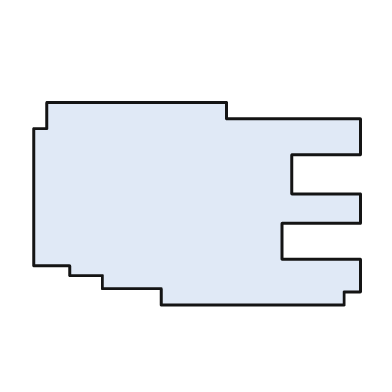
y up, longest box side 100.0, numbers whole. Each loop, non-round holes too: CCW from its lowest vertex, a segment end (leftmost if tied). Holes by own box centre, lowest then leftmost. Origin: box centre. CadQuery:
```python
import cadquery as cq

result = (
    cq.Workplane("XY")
    .moveTo(-11.0, -31.0)
    .lineTo(45.0, -31.0)
    .lineTo(45.0, -27.0)
    .lineTo(50.0, -27.0)
    .lineTo(50.0, -17.0)
    .lineTo(26.0, -17.0)
    .lineTo(26.0, -6.0)
    .lineTo(50.0, -6.0)
    .lineTo(50.0, 3.0)
    .lineTo(29.0, 3.0)
    .lineTo(29.0, 15.0)
    .lineTo(50.0, 15.0)
    .lineTo(50.0, 26.0)
    .lineTo(9.0, 26.0)
    .lineTo(9.0, 31.0)
    .lineTo(-46.0, 31.0)
    .lineTo(-46.0, 23.0)
    .lineTo(-50.0, 23.0)
    .lineTo(-50.0, -19.0)
    .lineTo(-39.0, -19.0)
    .lineTo(-39.0, -22.0)
    .lineTo(-29.0, -22.0)
    .lineTo(-29.0, -26.0)
    .lineTo(-11.0, -26.0)
    .close()
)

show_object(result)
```